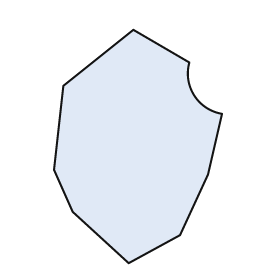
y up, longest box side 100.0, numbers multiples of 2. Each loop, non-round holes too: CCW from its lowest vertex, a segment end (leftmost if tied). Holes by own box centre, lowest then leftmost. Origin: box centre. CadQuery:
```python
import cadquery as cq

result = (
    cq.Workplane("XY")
    .moveTo(-4.0, -50.0)
    .lineTo(18.0, -38.0)
    .lineTo(30.0, -12.0)
    .lineTo(36.0, 14.0)
    .threePointArc((24.0, 22.0), (22.0, 36.0))
    .lineTo(-2.0, 50.0)
    .lineTo(-32.0, 26.0)
    .lineTo(-36.0, -10.0)
    .lineTo(-28.0, -28.0)
    .close()
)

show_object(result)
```